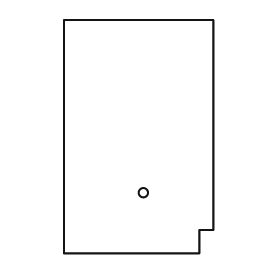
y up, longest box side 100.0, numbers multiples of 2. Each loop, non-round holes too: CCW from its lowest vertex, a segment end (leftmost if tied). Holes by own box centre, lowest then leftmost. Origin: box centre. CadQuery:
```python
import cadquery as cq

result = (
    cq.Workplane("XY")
    .moveTo(-32.0, -50.0)
    .lineTo(26.0, -50.0)
    .lineTo(26.0, -40.0)
    .lineTo(32.0, -40.0)
    .lineTo(32.0, 50.0)
    .lineTo(-32.0, 50.0)
    .close()
    .moveTo(2.0, -24.0)
    .circle(2.0)
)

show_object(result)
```